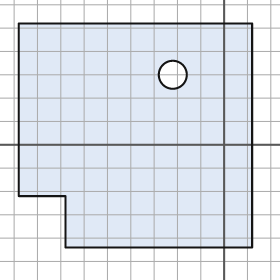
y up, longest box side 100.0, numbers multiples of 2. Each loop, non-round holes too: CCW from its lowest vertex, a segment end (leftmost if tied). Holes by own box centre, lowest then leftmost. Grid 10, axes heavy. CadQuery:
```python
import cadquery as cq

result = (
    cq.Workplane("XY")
    .moveTo(-68.0, -44.0)
    .lineTo(12.0, -44.0)
    .lineTo(12.0, 52.0)
    .lineTo(-88.0, 52.0)
    .lineTo(-88.0, -22.0)
    .lineTo(-68.0, -22.0)
    .close()
    .moveTo(-22.0, 30.0)
    .circle(6.0)
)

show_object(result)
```